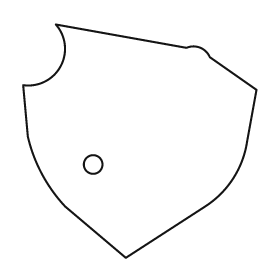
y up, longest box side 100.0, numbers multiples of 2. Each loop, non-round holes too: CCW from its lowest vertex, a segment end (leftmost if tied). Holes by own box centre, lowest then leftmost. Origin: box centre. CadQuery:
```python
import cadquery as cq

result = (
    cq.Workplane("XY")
    .moveTo(-6.0, -50.0)
    .lineTo(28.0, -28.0)
    .threePointArc((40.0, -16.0), (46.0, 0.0))
    .lineTo(50.0, 22.0)
    .lineTo(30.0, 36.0)
    .threePointArc((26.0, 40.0), (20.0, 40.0))
    .lineTo(-36.0, 50.0)
    .threePointArc((-34.0, 32.0), (-50.0, 24.0))
    .lineTo(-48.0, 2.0)
    .threePointArc((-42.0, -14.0), (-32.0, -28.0))
    .close()
    .moveTo(-20.0, -10.0)
    .circle(4.0)
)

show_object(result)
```